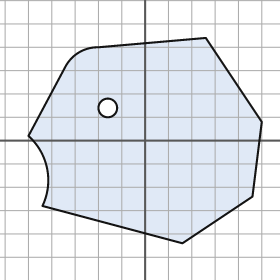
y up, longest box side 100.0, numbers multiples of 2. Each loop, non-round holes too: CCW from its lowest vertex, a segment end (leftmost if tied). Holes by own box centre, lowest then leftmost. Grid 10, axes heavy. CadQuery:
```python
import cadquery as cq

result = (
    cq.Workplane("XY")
    .moveTo(16.0, -44.0)
    .lineTo(46.0, -24.0)
    .lineTo(50.0, 8.0)
    .lineTo(26.0, 44.0)
    .lineTo(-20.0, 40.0)
    .threePointArc((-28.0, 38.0), (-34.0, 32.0))
    .lineTo(-50.0, 2.0)
    .threePointArc((-42.0, -12.0), (-44.0, -28.0))
    .close()
    .moveTo(-16.0, 14.0)
    .circle(4.0)
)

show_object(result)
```